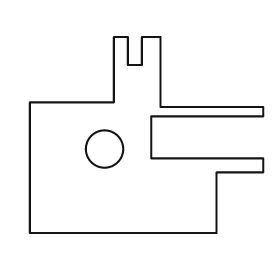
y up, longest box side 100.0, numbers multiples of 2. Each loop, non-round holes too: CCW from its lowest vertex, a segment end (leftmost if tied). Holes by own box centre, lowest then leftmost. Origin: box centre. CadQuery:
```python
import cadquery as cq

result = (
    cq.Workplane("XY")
    .moveTo(-50.0, -42.0)
    .lineTo(30.0, -42.0)
    .lineTo(30.0, -16.0)
    .lineTo(50.0, -16.0)
    .lineTo(50.0, -10.0)
    .lineTo(2.0, -10.0)
    .lineTo(2.0, 8.0)
    .lineTo(50.0, 8.0)
    .lineTo(50.0, 12.0)
    .lineTo(6.0, 12.0)
    .lineTo(6.0, 42.0)
    .lineTo(-2.0, 42.0)
    .lineTo(-2.0, 30.0)
    .lineTo(-8.0, 30.0)
    .lineTo(-8.0, 42.0)
    .lineTo(-14.0, 42.0)
    .lineTo(-14.0, 14.0)
    .lineTo(-50.0, 14.0)
    .close()
    .moveTo(-18.0, -6.0)
    .circle(8.0)
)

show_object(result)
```